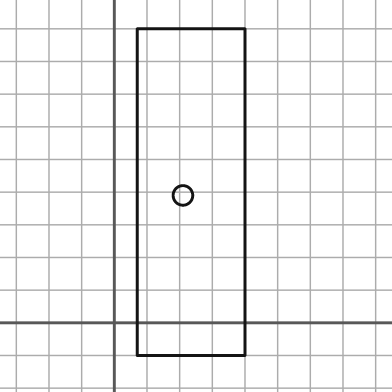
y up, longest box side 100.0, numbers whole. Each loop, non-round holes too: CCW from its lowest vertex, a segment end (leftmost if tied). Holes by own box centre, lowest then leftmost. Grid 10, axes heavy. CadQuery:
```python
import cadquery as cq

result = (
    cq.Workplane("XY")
    .moveTo(7.0, -10.0)
    .lineTo(40.0, -10.0)
    .lineTo(40.0, 90.0)
    .lineTo(7.0, 90.0)
    .close()
    .moveTo(21.0, 39.0)
    .circle(3.0)
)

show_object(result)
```